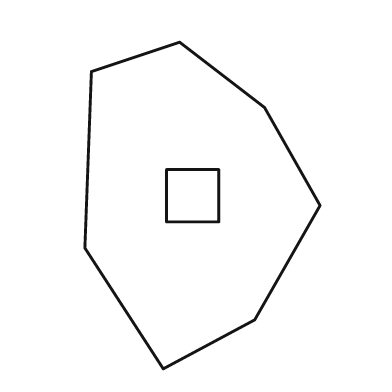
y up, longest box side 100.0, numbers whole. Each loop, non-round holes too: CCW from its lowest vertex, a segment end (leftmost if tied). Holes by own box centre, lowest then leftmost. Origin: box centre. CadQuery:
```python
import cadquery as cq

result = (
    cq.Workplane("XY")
    .moveTo(-12.0, -50.0)
    .lineTo(16.0, -35.0)
    .lineTo(36.0, 0.0)
    .lineTo(19.0, 30.0)
    .lineTo(-7.0, 50.0)
    .lineTo(-34.0, 41.0)
    .lineTo(-36.0, -13.0)
    .close()
    .moveTo(-11.0, -5.0)
    .lineTo(5.0, -5.0)
    .lineTo(5.0, 11.0)
    .lineTo(-11.0, 11.0)
    .close()
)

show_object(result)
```